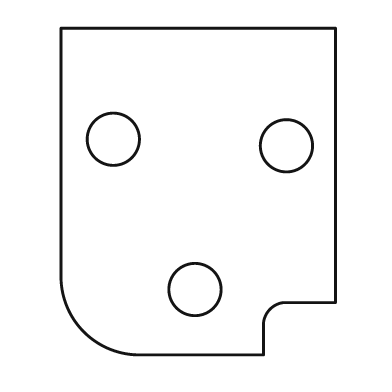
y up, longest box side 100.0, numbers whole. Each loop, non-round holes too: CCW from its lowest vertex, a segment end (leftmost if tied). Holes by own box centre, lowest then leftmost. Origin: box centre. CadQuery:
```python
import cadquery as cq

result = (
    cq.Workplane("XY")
    .moveTo(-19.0, -50.0)
    .lineTo(20.0, -50.0)
    .lineTo(20.0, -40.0)
    .threePointArc((22.0, -36.0), (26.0, -34.0))
    .lineTo(42.0, -34.0)
    .lineTo(42.0, 50.0)
    .lineTo(-42.0, 50.0)
    .lineTo(-42.0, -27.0)
    .threePointArc((-35.0, -43.0), (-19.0, -50.0))
    .close()
    .moveTo(-1.0, -30.0)
    .circle(8.0)
    .moveTo(27.0, 14.0)
    .circle(8.0)
    .moveTo(-26.0, 16.0)
    .circle(8.0)
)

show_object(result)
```